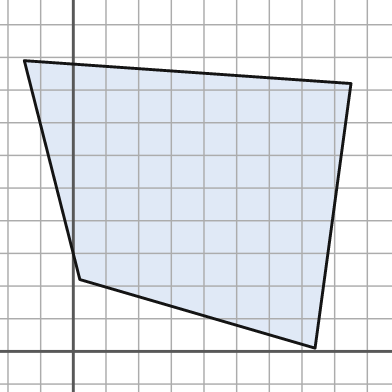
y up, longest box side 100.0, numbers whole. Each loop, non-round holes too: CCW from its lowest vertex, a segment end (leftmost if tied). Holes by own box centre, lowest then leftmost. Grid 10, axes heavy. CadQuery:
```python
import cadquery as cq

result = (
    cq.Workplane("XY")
    .moveTo(74.0, 1.0)
    .lineTo(85.0, 82.0)
    .lineTo(-15.0, 89.0)
    .lineTo(2.0, 22.0)
    .close()
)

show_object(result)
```